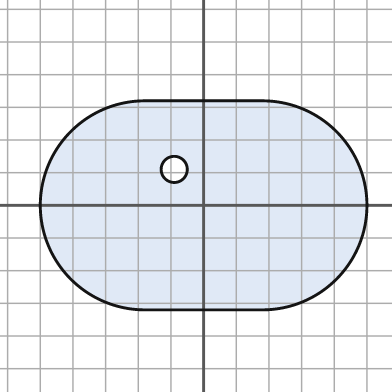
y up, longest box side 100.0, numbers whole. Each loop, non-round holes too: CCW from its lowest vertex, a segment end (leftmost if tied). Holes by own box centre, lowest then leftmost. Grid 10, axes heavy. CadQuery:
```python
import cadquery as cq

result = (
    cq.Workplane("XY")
    .moveTo(-18.0, -32.0)
    .lineTo(18.0, -32.0)
    .threePointArc((50.0, 0.0), (18.0, 32.0))
    .lineTo(-18.0, 32.0)
    .threePointArc((-50.0, 0.0), (-18.0, -32.0))
    .close()
    .moveTo(-9.0, 11.0)
    .circle(4.0)
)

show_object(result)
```